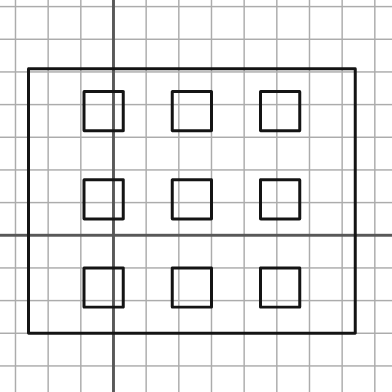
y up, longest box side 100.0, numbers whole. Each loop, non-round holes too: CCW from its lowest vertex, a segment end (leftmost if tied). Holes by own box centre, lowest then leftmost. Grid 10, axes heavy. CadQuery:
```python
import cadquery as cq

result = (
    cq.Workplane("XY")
    .moveTo(-26.0, -30.0)
    .lineTo(74.0, -30.0)
    .lineTo(74.0, 51.0)
    .lineTo(-26.0, 51.0)
    .close()
    .moveTo(-9.0, -22.0)
    .lineTo(3.0, -22.0)
    .lineTo(3.0, -10.0)
    .lineTo(-9.0, -10.0)
    .close()
    .moveTo(18.0, -22.0)
    .lineTo(30.0, -22.0)
    .lineTo(30.0, -10.0)
    .lineTo(18.0, -10.0)
    .close()
    .moveTo(45.0, -22.0)
    .lineTo(57.0, -22.0)
    .lineTo(57.0, -10.0)
    .lineTo(45.0, -10.0)
    .close()
    .moveTo(-9.0, 5.0)
    .lineTo(3.0, 5.0)
    .lineTo(3.0, 17.0)
    .lineTo(-9.0, 17.0)
    .close()
    .moveTo(18.0, 5.0)
    .lineTo(30.0, 5.0)
    .lineTo(30.0, 17.0)
    .lineTo(18.0, 17.0)
    .close()
    .moveTo(45.0, 5.0)
    .lineTo(57.0, 5.0)
    .lineTo(57.0, 17.0)
    .lineTo(45.0, 17.0)
    .close()
    .moveTo(-9.0, 32.0)
    .lineTo(3.0, 32.0)
    .lineTo(3.0, 44.0)
    .lineTo(-9.0, 44.0)
    .close()
    .moveTo(18.0, 32.0)
    .lineTo(30.0, 32.0)
    .lineTo(30.0, 44.0)
    .lineTo(18.0, 44.0)
    .close()
    .moveTo(45.0, 32.0)
    .lineTo(57.0, 32.0)
    .lineTo(57.0, 44.0)
    .lineTo(45.0, 44.0)
    .close()
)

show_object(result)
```